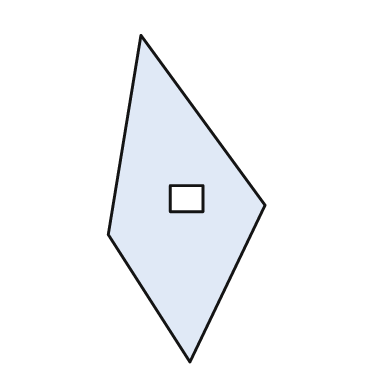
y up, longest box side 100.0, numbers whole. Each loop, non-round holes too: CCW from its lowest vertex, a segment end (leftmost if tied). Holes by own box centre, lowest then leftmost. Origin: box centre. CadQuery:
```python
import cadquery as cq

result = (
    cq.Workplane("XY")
    .moveTo(1.0, -50.0)
    .lineTo(24.0, -2.0)
    .lineTo(-14.0, 50.0)
    .lineTo(-24.0, -11.0)
    .close()
    .moveTo(-5.0, -4.0)
    .lineTo(5.0, -4.0)
    .lineTo(5.0, 4.0)
    .lineTo(-5.0, 4.0)
    .close()
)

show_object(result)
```